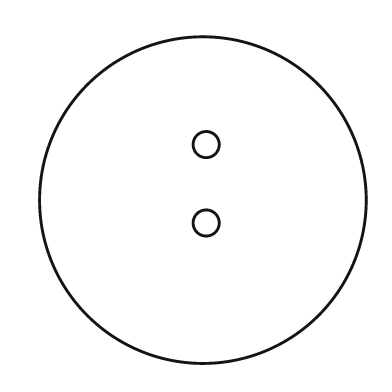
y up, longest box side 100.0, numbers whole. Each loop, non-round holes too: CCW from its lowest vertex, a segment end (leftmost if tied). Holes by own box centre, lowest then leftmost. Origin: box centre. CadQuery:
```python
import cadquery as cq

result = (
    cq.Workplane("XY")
    .moveTo(0.0, 0.0)
    .circle(50.0)
    .moveTo(1.0, -7.0)
    .circle(4.0)
    .moveTo(1.0, 17.0)
    .circle(4.0)
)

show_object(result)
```